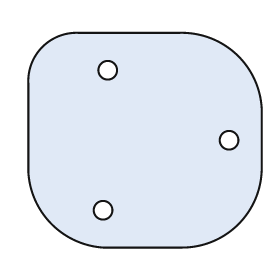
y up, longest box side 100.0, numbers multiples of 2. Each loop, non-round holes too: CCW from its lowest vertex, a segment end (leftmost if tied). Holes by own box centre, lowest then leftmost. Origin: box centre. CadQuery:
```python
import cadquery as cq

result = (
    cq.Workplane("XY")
    .moveTo(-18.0, -46.0)
    .lineTo(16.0, -46.0)
    .threePointArc((40.0, -36.0), (50.0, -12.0))
    .lineTo(50.0, 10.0)
    .threePointArc((40.0, 36.0), (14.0, 46.0))
    .lineTo(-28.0, 46.0)
    .threePointArc((-44.0, 40.0), (-50.0, 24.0))
    .lineTo(-50.0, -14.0)
    .threePointArc((-40.0, -36.0), (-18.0, -46.0))
    .close()
    .moveTo(-18.0, -30.0)
    .circle(4.0)
    .moveTo(36.0, 0.0)
    .circle(4.0)
    .moveTo(-16.0, 30.0)
    .circle(4.0)
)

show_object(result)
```